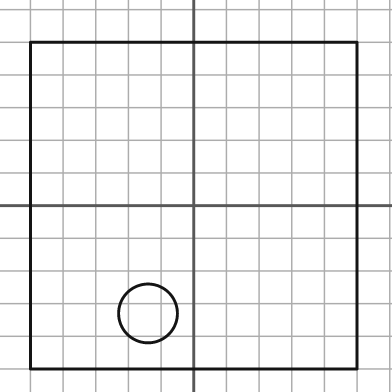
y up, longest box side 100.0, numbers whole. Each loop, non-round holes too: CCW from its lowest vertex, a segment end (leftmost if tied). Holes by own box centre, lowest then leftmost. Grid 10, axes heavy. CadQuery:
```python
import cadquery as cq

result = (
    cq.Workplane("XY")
    .moveTo(-50.0, -50.0)
    .lineTo(50.0, -50.0)
    .lineTo(50.0, 50.0)
    .lineTo(-50.0, 50.0)
    .close()
    .moveTo(-14.0, -33.0)
    .circle(9.0)
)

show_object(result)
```